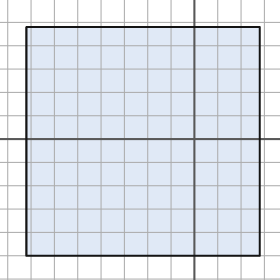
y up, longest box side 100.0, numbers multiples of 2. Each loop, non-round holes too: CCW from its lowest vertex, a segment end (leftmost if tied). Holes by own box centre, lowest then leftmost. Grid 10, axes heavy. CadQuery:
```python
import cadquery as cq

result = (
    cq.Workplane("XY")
    .moveTo(-72.0, -50.0)
    .lineTo(28.0, -50.0)
    .lineTo(28.0, 48.0)
    .lineTo(-72.0, 48.0)
    .close()
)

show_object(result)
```